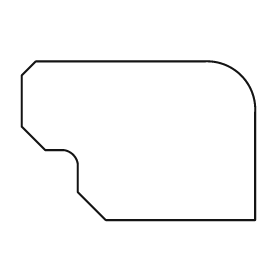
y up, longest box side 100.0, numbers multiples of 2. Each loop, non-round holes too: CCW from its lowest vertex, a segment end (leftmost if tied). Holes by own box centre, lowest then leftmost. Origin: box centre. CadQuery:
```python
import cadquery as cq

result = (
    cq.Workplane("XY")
    .moveTo(-14.0, -34.0)
    .lineTo(50.0, -34.0)
    .lineTo(50.0, 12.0)
    .threePointArc((44.0, 28.0), (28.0, 34.0))
    .lineTo(-44.0, 34.0)
    .lineTo(-50.0, 28.0)
    .lineTo(-50.0, 6.0)
    .lineTo(-40.0, -4.0)
    .lineTo(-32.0, -4.0)
    .threePointArc((-28.0, -6.0), (-26.0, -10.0))
    .lineTo(-26.0, -22.0)
    .close()
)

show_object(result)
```